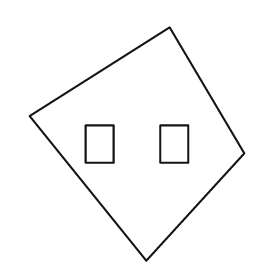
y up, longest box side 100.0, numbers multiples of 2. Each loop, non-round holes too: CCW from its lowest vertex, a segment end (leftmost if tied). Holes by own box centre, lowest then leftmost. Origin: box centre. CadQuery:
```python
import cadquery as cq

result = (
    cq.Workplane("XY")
    .moveTo(4.0, -50.0)
    .lineTo(46.0, -4.0)
    .lineTo(14.0, 50.0)
    .lineTo(-46.0, 12.0)
    .close()
    .moveTo(-22.0, -8.0)
    .lineTo(-10.0, -8.0)
    .lineTo(-10.0, 8.0)
    .lineTo(-22.0, 8.0)
    .close()
    .moveTo(10.0, -8.0)
    .lineTo(22.0, -8.0)
    .lineTo(22.0, 8.0)
    .lineTo(10.0, 8.0)
    .close()
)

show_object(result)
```